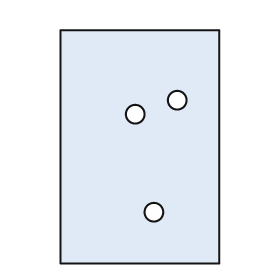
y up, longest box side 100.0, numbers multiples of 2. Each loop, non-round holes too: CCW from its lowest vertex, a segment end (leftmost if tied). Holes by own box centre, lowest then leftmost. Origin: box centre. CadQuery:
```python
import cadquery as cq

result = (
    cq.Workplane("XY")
    .moveTo(-34.0, -50.0)
    .lineTo(34.0, -50.0)
    .lineTo(34.0, 50.0)
    .lineTo(-34.0, 50.0)
    .close()
    .moveTo(6.0, -28.0)
    .circle(4.0)
    .moveTo(-2.0, 14.0)
    .circle(4.0)
    .moveTo(16.0, 20.0)
    .circle(4.0)
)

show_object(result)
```